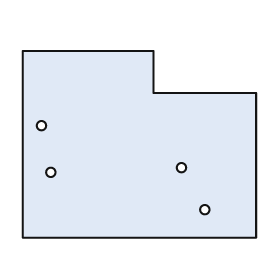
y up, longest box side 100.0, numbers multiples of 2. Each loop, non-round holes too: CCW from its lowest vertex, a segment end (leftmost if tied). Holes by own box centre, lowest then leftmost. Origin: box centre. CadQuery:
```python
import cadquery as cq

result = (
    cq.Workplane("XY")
    .moveTo(-50.0, -40.0)
    .lineTo(50.0, -40.0)
    .lineTo(50.0, 22.0)
    .lineTo(6.0, 22.0)
    .lineTo(6.0, 40.0)
    .lineTo(-50.0, 40.0)
    .close()
    .moveTo(28.0, -28.0)
    .circle(2.0)
    .moveTo(-38.0, -12.0)
    .circle(2.0)
    .moveTo(18.0, -10.0)
    .circle(2.0)
    .moveTo(-42.0, 8.0)
    .circle(2.0)
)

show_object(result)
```